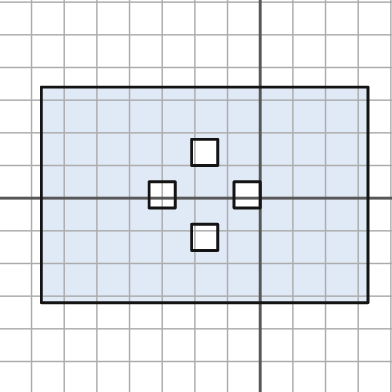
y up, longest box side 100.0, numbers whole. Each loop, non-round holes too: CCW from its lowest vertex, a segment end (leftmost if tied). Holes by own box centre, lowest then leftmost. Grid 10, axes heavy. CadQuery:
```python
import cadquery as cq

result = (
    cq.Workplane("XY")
    .moveTo(-67.0, -32.0)
    .lineTo(33.0, -32.0)
    .lineTo(33.0, 34.0)
    .lineTo(-67.0, 34.0)
    .close()
    .moveTo(-21.0, -16.0)
    .lineTo(-13.0, -16.0)
    .lineTo(-13.0, -8.0)
    .lineTo(-21.0, -8.0)
    .close()
    .moveTo(-34.0, -3.0)
    .lineTo(-26.0, -3.0)
    .lineTo(-26.0, 5.0)
    .lineTo(-34.0, 5.0)
    .close()
    .moveTo(-8.0, -3.0)
    .lineTo(0.0, -3.0)
    .lineTo(0.0, 5.0)
    .lineTo(-8.0, 5.0)
    .close()
    .moveTo(-21.0, 10.0)
    .lineTo(-13.0, 10.0)
    .lineTo(-13.0, 18.0)
    .lineTo(-21.0, 18.0)
    .close()
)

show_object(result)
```